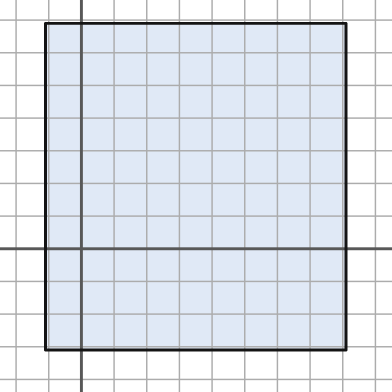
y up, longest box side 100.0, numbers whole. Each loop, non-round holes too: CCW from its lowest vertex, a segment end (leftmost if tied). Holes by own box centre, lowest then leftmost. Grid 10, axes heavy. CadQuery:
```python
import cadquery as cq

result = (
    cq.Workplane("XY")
    .moveTo(-11.0, -31.0)
    .lineTo(81.0, -31.0)
    .lineTo(81.0, 69.0)
    .lineTo(-11.0, 69.0)
    .close()
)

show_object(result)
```